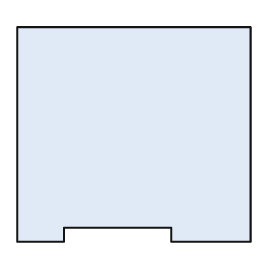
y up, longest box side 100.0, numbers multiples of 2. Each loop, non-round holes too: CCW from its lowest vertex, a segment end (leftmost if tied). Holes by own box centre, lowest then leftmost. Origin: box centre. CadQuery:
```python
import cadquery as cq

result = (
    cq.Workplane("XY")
    .moveTo(-50.0, -46.0)
    .lineTo(-30.0, -46.0)
    .lineTo(-30.0, -40.0)
    .lineTo(16.0, -40.0)
    .lineTo(16.0, -46.0)
    .lineTo(50.0, -46.0)
    .lineTo(50.0, 46.0)
    .lineTo(-50.0, 46.0)
    .close()
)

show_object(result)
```